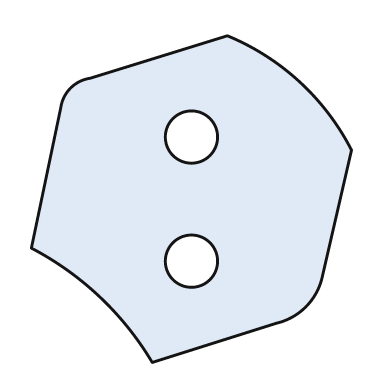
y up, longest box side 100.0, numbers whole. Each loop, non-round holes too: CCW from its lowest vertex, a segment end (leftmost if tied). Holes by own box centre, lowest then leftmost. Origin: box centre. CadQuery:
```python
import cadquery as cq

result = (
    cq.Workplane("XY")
    .moveTo(-12.0, -50.0)
    .lineTo(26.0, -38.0)
    .threePointArc((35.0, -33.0), (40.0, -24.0))
    .lineTo(49.0, 15.0)
    .threePointArc((33.0, 36.0), (11.0, 50.0))
    .lineTo(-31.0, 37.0)
    .threePointArc((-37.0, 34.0), (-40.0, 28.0))
    .lineTo(-49.0, -15.0)
    .threePointArc((-28.0, -30.0), (-12.0, -50.0))
    .close()
    .moveTo(0.0, -19.0)
    .circle(8.0)
    .moveTo(0.0, 19.0)
    .circle(8.0)
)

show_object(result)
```